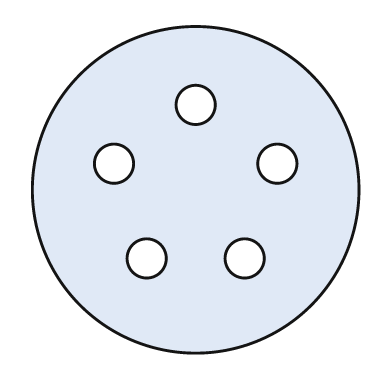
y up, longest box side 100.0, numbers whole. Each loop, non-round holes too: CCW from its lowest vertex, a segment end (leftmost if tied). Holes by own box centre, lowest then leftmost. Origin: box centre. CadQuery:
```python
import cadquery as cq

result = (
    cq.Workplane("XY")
    .moveTo(0.0, 0.0)
    .circle(50.0)
    .moveTo(-15.0, -21.0)
    .circle(6.0)
    .moveTo(15.0, -21.0)
    .circle(6.0)
    .moveTo(-25.0, 8.0)
    .circle(6.0)
    .moveTo(25.0, 8.0)
    .circle(6.0)
    .moveTo(0.0, 26.0)
    .circle(6.0)
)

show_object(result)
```